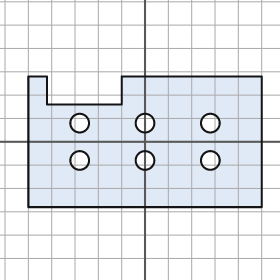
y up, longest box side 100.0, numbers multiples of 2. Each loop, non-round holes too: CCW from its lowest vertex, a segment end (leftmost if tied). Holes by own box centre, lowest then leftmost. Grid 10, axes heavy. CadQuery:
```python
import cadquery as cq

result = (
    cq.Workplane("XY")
    .moveTo(-50.0, -28.0)
    .lineTo(50.0, -28.0)
    .lineTo(50.0, 28.0)
    .lineTo(-10.0, 28.0)
    .lineTo(-10.0, 16.0)
    .lineTo(-42.0, 16.0)
    .lineTo(-42.0, 28.0)
    .lineTo(-50.0, 28.0)
    .close()
    .moveTo(-28.0, -8.0)
    .circle(4.0)
    .moveTo(0.0, -8.0)
    .circle(4.0)
    .moveTo(28.0, -8.0)
    .circle(4.0)
    .moveTo(-28.0, 8.0)
    .circle(4.0)
    .moveTo(0.0, 8.0)
    .circle(4.0)
    .moveTo(28.0, 8.0)
    .circle(4.0)
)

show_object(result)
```